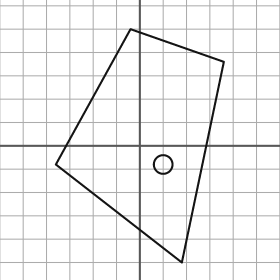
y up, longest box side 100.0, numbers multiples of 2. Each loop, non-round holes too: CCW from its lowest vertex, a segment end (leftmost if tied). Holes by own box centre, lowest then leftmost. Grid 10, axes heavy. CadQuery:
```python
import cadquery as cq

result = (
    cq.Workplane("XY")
    .moveTo(18.0, -50.0)
    .lineTo(36.0, 36.0)
    .lineTo(-4.0, 50.0)
    .lineTo(-36.0, -8.0)
    .close()
    .moveTo(10.0, -8.0)
    .circle(4.0)
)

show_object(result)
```